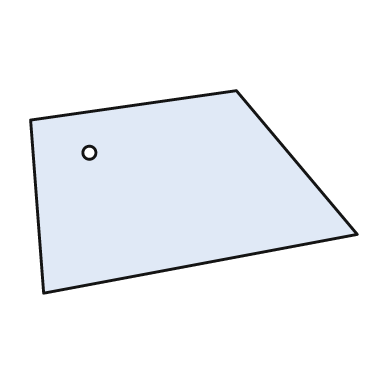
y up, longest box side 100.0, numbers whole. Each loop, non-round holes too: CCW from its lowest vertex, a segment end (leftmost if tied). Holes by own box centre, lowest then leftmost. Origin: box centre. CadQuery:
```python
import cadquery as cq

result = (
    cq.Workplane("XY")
    .moveTo(-46.0, -31.0)
    .lineTo(50.0, -13.0)
    .lineTo(13.0, 31.0)
    .lineTo(-50.0, 22.0)
    .close()
    .moveTo(-32.0, 12.0)
    .circle(2.0)
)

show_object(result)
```